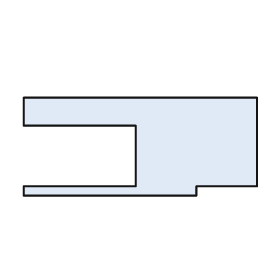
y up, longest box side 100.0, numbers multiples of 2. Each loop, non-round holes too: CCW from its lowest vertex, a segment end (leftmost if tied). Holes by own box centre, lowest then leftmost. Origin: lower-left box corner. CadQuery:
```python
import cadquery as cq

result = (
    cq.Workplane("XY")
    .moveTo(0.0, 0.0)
    .lineTo(74.0, 0.0)
    .lineTo(74.0, 4.0)
    .lineTo(100.0, 4.0)
    .lineTo(100.0, 42.0)
    .lineTo(0.0, 42.0)
    .lineTo(0.0, 30.0)
    .lineTo(48.0, 30.0)
    .lineTo(48.0, 4.0)
    .lineTo(0.0, 4.0)
    .close()
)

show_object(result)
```